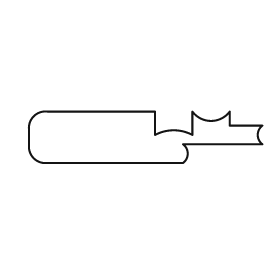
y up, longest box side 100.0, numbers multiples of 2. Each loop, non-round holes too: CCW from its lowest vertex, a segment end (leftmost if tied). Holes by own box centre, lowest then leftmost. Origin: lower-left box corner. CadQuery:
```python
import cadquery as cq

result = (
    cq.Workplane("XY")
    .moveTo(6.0, 0.0)
    .lineTo(66.0, 0.0)
    .threePointArc((68.0, 4.0), (66.0, 8.0))
    .lineTo(100.0, 8.0)
    .threePointArc((98.0, 12.0), (100.0, 16.0))
    .lineTo(86.0, 16.0)
    .lineTo(86.0, 22.0)
    .threePointArc((78.0, 18.0), (70.0, 22.0))
    .lineTo(70.0, 12.0)
    .threePointArc((62.0, 14.0), (54.0, 12.0))
    .lineTo(54.0, 22.0)
    .lineTo(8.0, 22.0)
    .threePointArc((2.0, 20.0), (0.0, 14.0))
    .lineTo(0.0, 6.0)
    .threePointArc((2.0, 2.0), (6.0, 0.0))
    .close()
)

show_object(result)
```